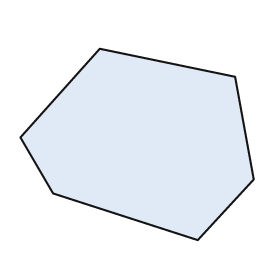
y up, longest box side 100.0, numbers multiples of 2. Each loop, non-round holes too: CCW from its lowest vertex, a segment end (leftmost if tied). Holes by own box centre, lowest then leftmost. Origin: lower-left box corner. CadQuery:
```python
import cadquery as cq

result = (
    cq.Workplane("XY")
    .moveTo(76.0, 0.0)
    .lineTo(100.0, 26.0)
    .lineTo(92.0, 70.0)
    .lineTo(34.0, 82.0)
    .lineTo(0.0, 44.0)
    .lineTo(14.0, 20.0)
    .close()
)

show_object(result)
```